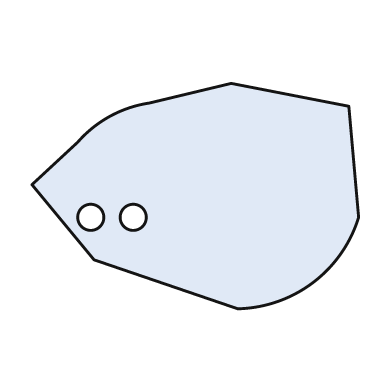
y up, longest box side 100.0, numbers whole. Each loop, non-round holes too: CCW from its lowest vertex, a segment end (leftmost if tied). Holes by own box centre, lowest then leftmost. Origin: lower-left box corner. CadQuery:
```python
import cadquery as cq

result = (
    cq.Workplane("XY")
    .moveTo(63.0, 0.0)
    .threePointArc((86.0, 8.0), (100.0, 28.0))
    .lineTo(97.0, 62.0)
    .lineTo(61.0, 69.0)
    .lineTo(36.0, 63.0)
    .threePointArc((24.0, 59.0), (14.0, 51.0))
    .lineTo(0.0, 38.0)
    .lineTo(19.0, 15.0)
    .close()
    .moveTo(18.0, 28.0)
    .circle(4.0)
    .moveTo(31.0, 28.0)
    .circle(4.0)
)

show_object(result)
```